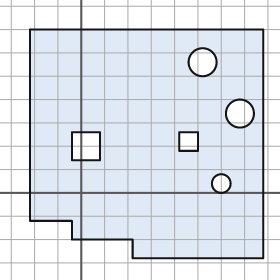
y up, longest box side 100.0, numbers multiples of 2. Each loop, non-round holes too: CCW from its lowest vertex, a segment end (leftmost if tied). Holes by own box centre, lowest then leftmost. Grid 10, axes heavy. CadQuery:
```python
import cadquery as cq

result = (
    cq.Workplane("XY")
    .moveTo(22.0, -28.0)
    .lineTo(78.0, -28.0)
    .lineTo(78.0, 70.0)
    .lineTo(-22.0, 70.0)
    .lineTo(-22.0, -12.0)
    .lineTo(-4.0, -12.0)
    .lineTo(-4.0, -20.0)
    .lineTo(22.0, -20.0)
    .close()
    .moveTo(60.0, 4.0)
    .circle(4.0)
    .moveTo(-4.0, 14.0)
    .lineTo(8.0, 14.0)
    .lineTo(8.0, 26.0)
    .lineTo(-4.0, 26.0)
    .close()
    .moveTo(42.0, 18.0)
    .lineTo(50.0, 18.0)
    .lineTo(50.0, 26.0)
    .lineTo(42.0, 26.0)
    .close()
    .moveTo(68.0, 34.0)
    .circle(6.0)
    .moveTo(52.0, 56.0)
    .circle(6.0)
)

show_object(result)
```